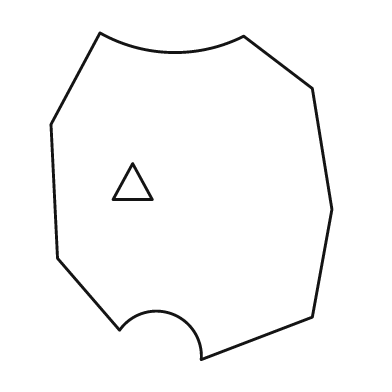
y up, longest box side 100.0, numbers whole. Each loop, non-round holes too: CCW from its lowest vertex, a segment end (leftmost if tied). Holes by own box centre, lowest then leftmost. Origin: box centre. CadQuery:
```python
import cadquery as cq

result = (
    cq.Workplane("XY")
    .moveTo(3.0, -50.0)
    .lineTo(37.0, -37.0)
    .lineTo(43.0, -4.0)
    .lineTo(37.0, 33.0)
    .lineTo(16.0, 49.0)
    .threePointArc((-6.0, 44.0), (-28.0, 50.0))
    .lineTo(-43.0, 22.0)
    .lineTo(-41.0, -19.0)
    .lineTo(-22.0, -41.0)
    .threePointArc((-6.0, -36.0), (3.0, -50.0))
    .close()
    .moveTo(-24.0, -1.0)
    .lineTo(-12.0, -1.0)
    .lineTo(-18.0, 10.0)
    .close()
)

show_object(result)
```